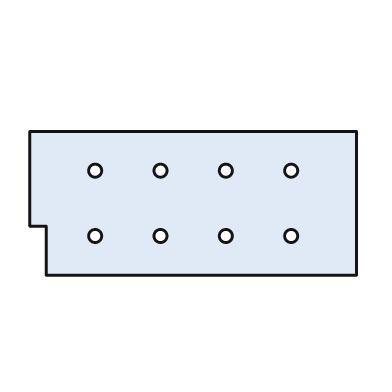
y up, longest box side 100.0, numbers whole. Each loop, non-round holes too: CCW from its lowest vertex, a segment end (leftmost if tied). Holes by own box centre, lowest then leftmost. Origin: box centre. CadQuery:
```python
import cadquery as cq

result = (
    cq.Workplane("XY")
    .moveTo(-45.0, -22.0)
    .lineTo(50.0, -22.0)
    .lineTo(50.0, 22.0)
    .lineTo(-50.0, 22.0)
    .lineTo(-50.0, -7.0)
    .lineTo(-45.0, -7.0)
    .close()
    .moveTo(-30.0, -10.0)
    .circle(2.0)
    .moveTo(-10.0, -10.0)
    .circle(2.0)
    .moveTo(10.0, -10.0)
    .circle(2.0)
    .moveTo(30.0, -10.0)
    .circle(2.0)
    .moveTo(-30.0, 10.0)
    .circle(2.0)
    .moveTo(-10.0, 10.0)
    .circle(2.0)
    .moveTo(10.0, 10.0)
    .circle(2.0)
    .moveTo(30.0, 10.0)
    .circle(2.0)
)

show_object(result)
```